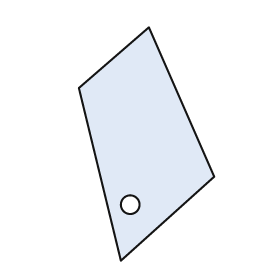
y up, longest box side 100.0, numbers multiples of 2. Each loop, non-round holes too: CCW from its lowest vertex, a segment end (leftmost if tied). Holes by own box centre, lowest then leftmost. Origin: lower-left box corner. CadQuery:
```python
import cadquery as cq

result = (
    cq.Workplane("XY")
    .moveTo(18.0, 0.0)
    .lineTo(58.0, 36.0)
    .lineTo(30.0, 100.0)
    .lineTo(0.0, 74.0)
    .close()
    .moveTo(22.0, 24.0)
    .circle(4.0)
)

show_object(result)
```